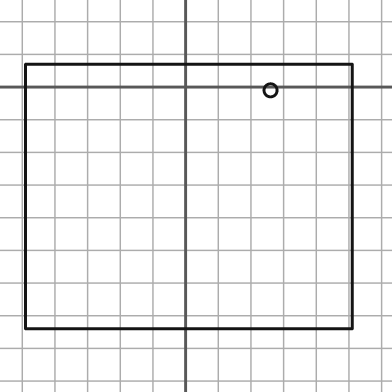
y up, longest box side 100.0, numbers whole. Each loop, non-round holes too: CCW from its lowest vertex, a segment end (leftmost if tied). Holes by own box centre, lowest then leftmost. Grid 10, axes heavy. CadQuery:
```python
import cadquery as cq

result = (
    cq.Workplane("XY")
    .moveTo(-49.0, -74.0)
    .lineTo(51.0, -74.0)
    .lineTo(51.0, 7.0)
    .lineTo(-49.0, 7.0)
    .close()
    .moveTo(26.0, -1.0)
    .circle(2.0)
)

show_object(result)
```